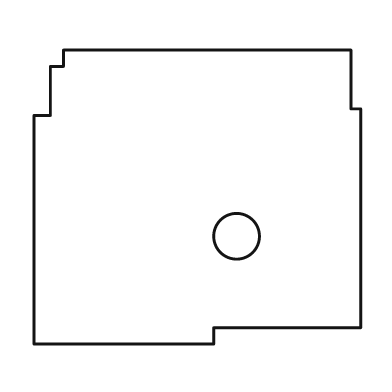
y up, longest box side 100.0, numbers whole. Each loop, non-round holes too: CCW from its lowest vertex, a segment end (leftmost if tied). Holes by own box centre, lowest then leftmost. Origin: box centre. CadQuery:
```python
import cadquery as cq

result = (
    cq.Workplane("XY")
    .moveTo(-50.0, -45.0)
    .lineTo(5.0, -45.0)
    .lineTo(5.0, -40.0)
    .lineTo(50.0, -40.0)
    .lineTo(50.0, 27.0)
    .lineTo(47.0, 27.0)
    .lineTo(47.0, 45.0)
    .lineTo(-41.0, 45.0)
    .lineTo(-41.0, 40.0)
    .lineTo(-45.0, 40.0)
    .lineTo(-45.0, 25.0)
    .lineTo(-50.0, 25.0)
    .close()
    .moveTo(12.0, -12.0)
    .circle(7.0)
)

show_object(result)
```